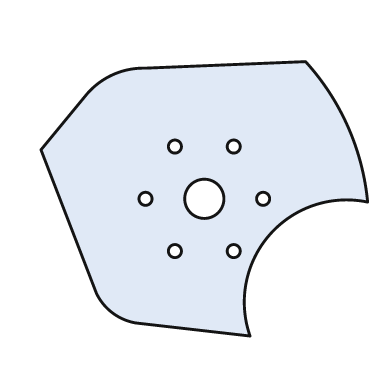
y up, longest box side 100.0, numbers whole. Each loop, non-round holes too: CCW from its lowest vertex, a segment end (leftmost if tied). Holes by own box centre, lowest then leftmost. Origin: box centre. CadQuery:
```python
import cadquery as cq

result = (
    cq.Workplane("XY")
    .moveTo(14.0, -42.0)
    .threePointArc((20.0, -11.0), (50.0, -1.0))
    .threePointArc((44.0, 22.0), (31.0, 42.0))
    .lineTo(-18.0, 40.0)
    .threePointArc((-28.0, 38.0), (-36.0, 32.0))
    .lineTo(-50.0, 15.0)
    .lineTo(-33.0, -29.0)
    .threePointArc((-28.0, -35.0), (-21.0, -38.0))
    .close()
    .moveTo(-9.0, -16.0)
    .circle(2.0)
    .moveTo(9.0, -16.0)
    .circle(2.0)
    .moveTo(-18.0, 0.0)
    .circle(2.0)
    .moveTo(0.0, 0.0)
    .circle(6.0)
    .moveTo(18.0, 0.0)
    .circle(2.0)
    .moveTo(-9.0, 16.0)
    .circle(2.0)
    .moveTo(9.0, 16.0)
    .circle(2.0)
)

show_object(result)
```